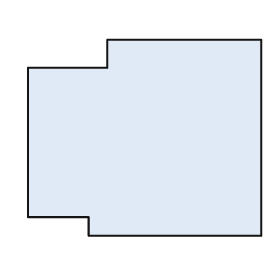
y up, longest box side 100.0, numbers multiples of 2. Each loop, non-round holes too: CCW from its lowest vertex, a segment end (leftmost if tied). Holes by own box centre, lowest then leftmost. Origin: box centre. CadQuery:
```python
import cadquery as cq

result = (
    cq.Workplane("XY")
    .moveTo(-24.0, -42.0)
    .lineTo(50.0, -42.0)
    .lineTo(50.0, 42.0)
    .lineTo(-16.0, 42.0)
    .lineTo(-16.0, 30.0)
    .lineTo(-50.0, 30.0)
    .lineTo(-50.0, -34.0)
    .lineTo(-24.0, -34.0)
    .close()
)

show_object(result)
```